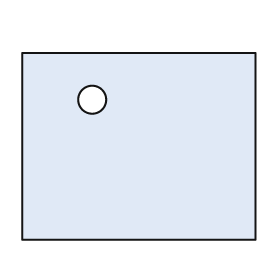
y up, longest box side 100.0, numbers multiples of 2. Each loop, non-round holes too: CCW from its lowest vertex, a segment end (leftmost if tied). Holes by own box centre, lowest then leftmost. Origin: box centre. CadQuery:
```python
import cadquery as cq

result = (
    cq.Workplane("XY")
    .moveTo(-50.0, -40.0)
    .lineTo(50.0, -40.0)
    .lineTo(50.0, 40.0)
    .lineTo(-50.0, 40.0)
    .close()
    .moveTo(-20.0, 20.0)
    .circle(6.0)
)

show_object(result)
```